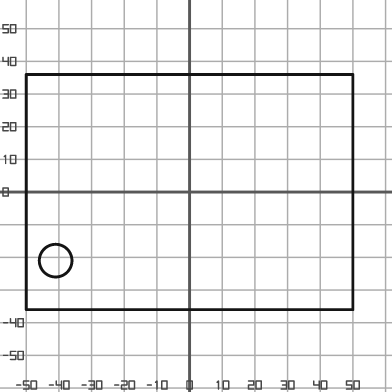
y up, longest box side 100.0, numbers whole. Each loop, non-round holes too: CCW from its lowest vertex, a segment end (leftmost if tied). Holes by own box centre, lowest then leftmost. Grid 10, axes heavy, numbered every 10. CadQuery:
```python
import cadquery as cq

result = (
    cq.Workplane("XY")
    .moveTo(-50.0, -36.0)
    .lineTo(50.0, -36.0)
    .lineTo(50.0, 36.0)
    .lineTo(-50.0, 36.0)
    .close()
    .moveTo(-41.0, -21.0)
    .circle(5.0)
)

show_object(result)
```